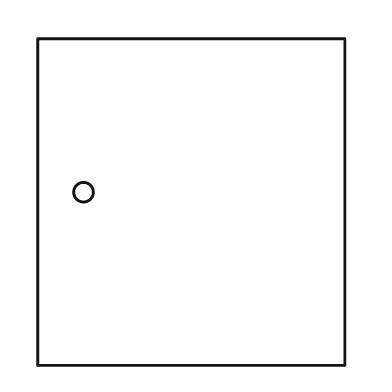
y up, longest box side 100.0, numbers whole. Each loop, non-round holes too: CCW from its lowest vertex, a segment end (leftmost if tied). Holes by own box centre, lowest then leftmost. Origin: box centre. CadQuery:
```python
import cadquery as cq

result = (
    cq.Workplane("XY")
    .moveTo(-47.0, -50.0)
    .lineTo(47.0, -50.0)
    .lineTo(47.0, 50.0)
    .lineTo(-47.0, 50.0)
    .close()
    .moveTo(-33.0, 3.0)
    .circle(3.0)
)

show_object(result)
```